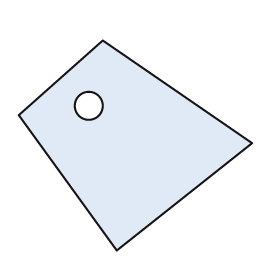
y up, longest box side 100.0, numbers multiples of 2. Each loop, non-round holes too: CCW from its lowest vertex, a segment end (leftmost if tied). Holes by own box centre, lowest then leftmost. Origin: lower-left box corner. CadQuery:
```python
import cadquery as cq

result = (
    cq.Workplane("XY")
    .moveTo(42.0, 0.0)
    .lineTo(100.0, 46.0)
    .lineTo(36.0, 90.0)
    .lineTo(0.0, 58.0)
    .close()
    .moveTo(30.0, 62.0)
    .circle(6.0)
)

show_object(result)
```